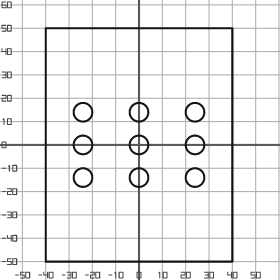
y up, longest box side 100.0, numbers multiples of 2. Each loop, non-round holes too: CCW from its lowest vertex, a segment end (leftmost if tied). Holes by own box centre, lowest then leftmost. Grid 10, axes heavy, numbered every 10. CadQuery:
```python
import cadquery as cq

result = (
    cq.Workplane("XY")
    .moveTo(-40.0, -50.0)
    .lineTo(40.0, -50.0)
    .lineTo(40.0, 50.0)
    .lineTo(-40.0, 50.0)
    .close()
    .moveTo(-24.0, -14.0)
    .circle(4.0)
    .moveTo(0.0, -14.0)
    .circle(4.0)
    .moveTo(24.0, -14.0)
    .circle(4.0)
    .moveTo(-24.0, 0.0)
    .circle(4.0)
    .moveTo(0.0, 0.0)
    .circle(4.0)
    .moveTo(24.0, 0.0)
    .circle(4.0)
    .moveTo(-24.0, 14.0)
    .circle(4.0)
    .moveTo(0.0, 14.0)
    .circle(4.0)
    .moveTo(24.0, 14.0)
    .circle(4.0)
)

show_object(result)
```